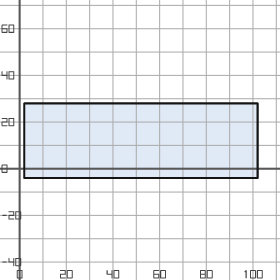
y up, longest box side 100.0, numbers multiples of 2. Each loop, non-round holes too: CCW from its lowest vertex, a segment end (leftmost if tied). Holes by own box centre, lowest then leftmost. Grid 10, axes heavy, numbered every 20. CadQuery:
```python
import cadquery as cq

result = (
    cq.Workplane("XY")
    .moveTo(2.0, -4.0)
    .lineTo(102.0, -4.0)
    .lineTo(102.0, 28.0)
    .lineTo(2.0, 28.0)
    .close()
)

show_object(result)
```